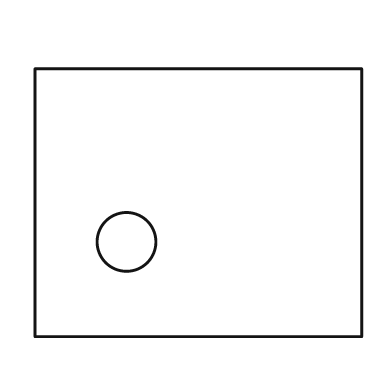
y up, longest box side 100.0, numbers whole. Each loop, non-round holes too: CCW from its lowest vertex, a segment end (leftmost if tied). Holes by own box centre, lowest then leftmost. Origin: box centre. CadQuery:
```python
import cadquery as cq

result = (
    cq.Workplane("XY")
    .moveTo(-50.0, -41.0)
    .lineTo(50.0, -41.0)
    .lineTo(50.0, 41.0)
    .lineTo(-50.0, 41.0)
    .close()
    .moveTo(-22.0, -12.0)
    .circle(9.0)
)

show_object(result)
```